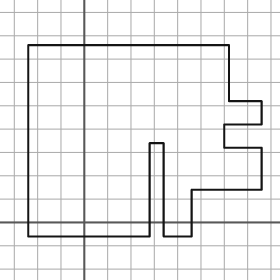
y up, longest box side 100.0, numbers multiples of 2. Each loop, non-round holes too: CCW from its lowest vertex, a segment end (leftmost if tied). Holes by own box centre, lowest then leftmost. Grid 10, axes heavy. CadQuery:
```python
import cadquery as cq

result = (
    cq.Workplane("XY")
    .moveTo(-24.0, -6.0)
    .lineTo(28.0, -6.0)
    .lineTo(28.0, 34.0)
    .lineTo(34.0, 34.0)
    .lineTo(34.0, -6.0)
    .lineTo(46.0, -6.0)
    .lineTo(46.0, 14.0)
    .lineTo(76.0, 14.0)
    .lineTo(76.0, 32.0)
    .lineTo(60.0, 32.0)
    .lineTo(60.0, 42.0)
    .lineTo(76.0, 42.0)
    .lineTo(76.0, 52.0)
    .lineTo(62.0, 52.0)
    .lineTo(62.0, 76.0)
    .lineTo(-24.0, 76.0)
    .close()
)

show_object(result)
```